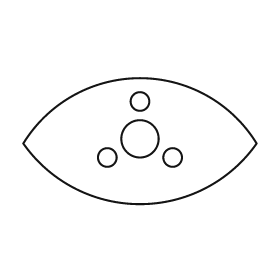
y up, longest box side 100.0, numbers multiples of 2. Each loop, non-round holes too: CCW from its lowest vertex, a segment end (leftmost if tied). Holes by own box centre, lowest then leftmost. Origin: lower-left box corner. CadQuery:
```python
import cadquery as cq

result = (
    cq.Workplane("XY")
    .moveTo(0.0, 26.0)
    .threePointArc((50.0, 0.0), (100.0, 26.0))
    .threePointArc((50.0, 54.0), (0.0, 26.0))
    .close()
    .moveTo(36.0, 20.0)
    .circle(4.0)
    .moveTo(64.0, 20.0)
    .circle(4.0)
    .moveTo(50.0, 28.0)
    .circle(8.0)
    .moveTo(50.0, 44.0)
    .circle(4.0)
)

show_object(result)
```